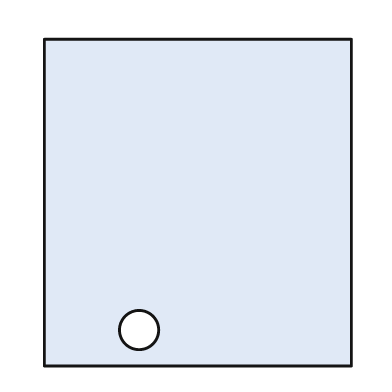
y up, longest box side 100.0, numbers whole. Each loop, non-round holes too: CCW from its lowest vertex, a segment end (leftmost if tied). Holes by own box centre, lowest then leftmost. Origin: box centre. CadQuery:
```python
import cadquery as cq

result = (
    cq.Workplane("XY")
    .moveTo(-47.0, -50.0)
    .lineTo(47.0, -50.0)
    .lineTo(47.0, 50.0)
    .lineTo(-47.0, 50.0)
    .close()
    .moveTo(-18.0, -39.0)
    .circle(6.0)
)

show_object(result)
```